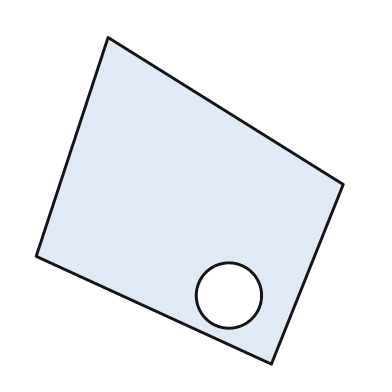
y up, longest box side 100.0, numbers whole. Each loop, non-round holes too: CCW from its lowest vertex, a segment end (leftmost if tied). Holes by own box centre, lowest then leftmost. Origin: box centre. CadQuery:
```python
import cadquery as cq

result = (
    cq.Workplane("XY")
    .moveTo(25.0, -50.0)
    .lineTo(47.0, 5.0)
    .lineTo(-25.0, 50.0)
    .lineTo(-47.0, -17.0)
    .close()
    .moveTo(12.0, -29.0)
    .circle(10.0)
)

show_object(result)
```